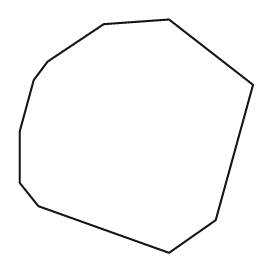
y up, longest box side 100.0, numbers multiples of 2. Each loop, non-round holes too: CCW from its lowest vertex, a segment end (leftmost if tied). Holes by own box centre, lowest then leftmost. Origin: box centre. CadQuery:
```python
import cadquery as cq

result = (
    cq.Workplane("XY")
    .moveTo(14.0, -50.0)
    .lineTo(34.0, -36.0)
    .lineTo(50.0, 22.0)
    .lineTo(14.0, 50.0)
    .lineTo(-14.0, 48.0)
    .lineTo(-38.0, 32.0)
    .lineTo(-44.0, 24.0)
    .lineTo(-50.0, 2.0)
    .lineTo(-50.0, -20.0)
    .lineTo(-42.0, -30.0)
    .close()
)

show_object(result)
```